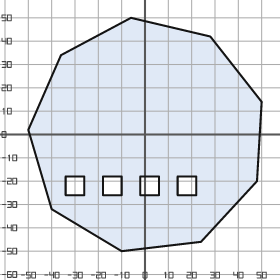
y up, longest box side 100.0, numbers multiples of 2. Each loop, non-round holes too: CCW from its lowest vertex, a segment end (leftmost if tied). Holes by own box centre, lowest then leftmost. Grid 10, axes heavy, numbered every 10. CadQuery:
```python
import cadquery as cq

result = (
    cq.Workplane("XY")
    .moveTo(-10.0, -50.0)
    .lineTo(24.0, -46.0)
    .lineTo(48.0, -20.0)
    .lineTo(50.0, 14.0)
    .lineTo(28.0, 42.0)
    .lineTo(-6.0, 50.0)
    .lineTo(-36.0, 34.0)
    .lineTo(-50.0, 2.0)
    .lineTo(-40.0, -32.0)
    .close()
    .moveTo(-34.0, -26.0)
    .lineTo(-26.0, -26.0)
    .lineTo(-26.0, -18.0)
    .lineTo(-34.0, -18.0)
    .close()
    .moveTo(-18.0, -26.0)
    .lineTo(-10.0, -26.0)
    .lineTo(-10.0, -18.0)
    .lineTo(-18.0, -18.0)
    .close()
    .moveTo(-2.0, -26.0)
    .lineTo(6.0, -26.0)
    .lineTo(6.0, -18.0)
    .lineTo(-2.0, -18.0)
    .close()
    .moveTo(14.0, -26.0)
    .lineTo(22.0, -26.0)
    .lineTo(22.0, -18.0)
    .lineTo(14.0, -18.0)
    .close()
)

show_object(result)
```